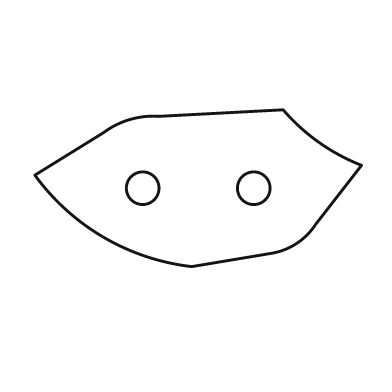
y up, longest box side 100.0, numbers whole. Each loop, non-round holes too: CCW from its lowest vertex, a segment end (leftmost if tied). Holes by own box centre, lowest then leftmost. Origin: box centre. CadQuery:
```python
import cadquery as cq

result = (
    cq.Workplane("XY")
    .moveTo(-2.0, -24.0)
    .lineTo(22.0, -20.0)
    .threePointArc((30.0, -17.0), (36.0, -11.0))
    .lineTo(50.0, 7.0)
    .threePointArc((37.0, 14.0), (26.0, 24.0))
    .lineTo(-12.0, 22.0)
    .threePointArc((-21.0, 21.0), (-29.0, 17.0))
    .lineTo(-50.0, 4.0)
    .threePointArc((-29.0, -15.0), (-2.0, -24.0))
    .close()
    .moveTo(-17.0, 0.0)
    .circle(5.0)
    .moveTo(17.0, 0.0)
    .circle(5.0)
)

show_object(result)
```